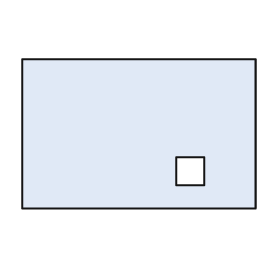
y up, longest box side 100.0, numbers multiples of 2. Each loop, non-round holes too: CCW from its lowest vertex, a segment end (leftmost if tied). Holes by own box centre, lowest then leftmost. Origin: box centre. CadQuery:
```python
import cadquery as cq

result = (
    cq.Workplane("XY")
    .moveTo(-50.0, -32.0)
    .lineTo(50.0, -32.0)
    .lineTo(50.0, 32.0)
    .lineTo(-50.0, 32.0)
    .close()
    .moveTo(16.0, -22.0)
    .lineTo(28.0, -22.0)
    .lineTo(28.0, -10.0)
    .lineTo(16.0, -10.0)
    .close()
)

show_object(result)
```